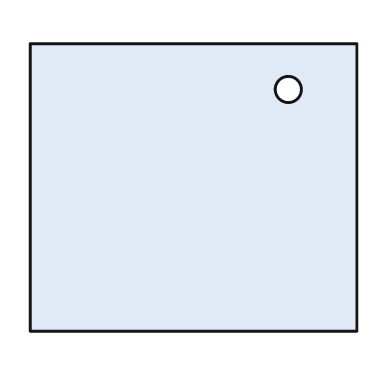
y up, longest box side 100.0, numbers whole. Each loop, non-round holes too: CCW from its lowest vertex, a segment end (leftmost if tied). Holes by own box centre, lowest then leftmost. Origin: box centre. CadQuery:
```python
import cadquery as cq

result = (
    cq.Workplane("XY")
    .moveTo(-50.0, -44.0)
    .lineTo(50.0, -44.0)
    .lineTo(50.0, 44.0)
    .lineTo(-50.0, 44.0)
    .close()
    .moveTo(29.0, 30.0)
    .circle(4.0)
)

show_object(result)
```